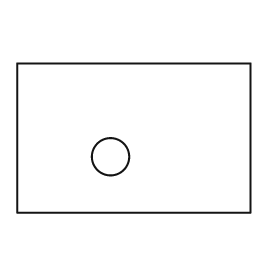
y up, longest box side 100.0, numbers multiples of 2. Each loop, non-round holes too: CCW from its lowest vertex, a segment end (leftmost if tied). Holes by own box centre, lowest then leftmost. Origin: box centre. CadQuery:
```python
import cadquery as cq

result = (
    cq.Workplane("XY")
    .moveTo(-50.0, -32.0)
    .lineTo(50.0, -32.0)
    .lineTo(50.0, 32.0)
    .lineTo(-50.0, 32.0)
    .close()
    .moveTo(-10.0, -8.0)
    .circle(8.0)
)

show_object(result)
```